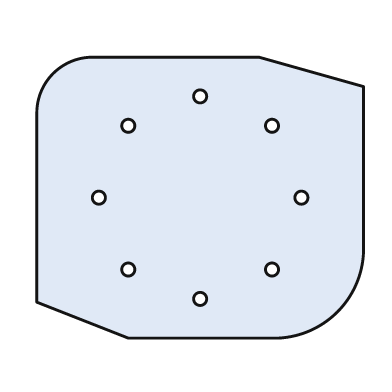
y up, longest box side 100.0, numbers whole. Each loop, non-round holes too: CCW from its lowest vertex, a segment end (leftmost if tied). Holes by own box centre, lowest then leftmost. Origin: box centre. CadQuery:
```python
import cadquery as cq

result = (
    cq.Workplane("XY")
    .moveTo(-22.0, -43.0)
    .lineTo(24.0, -43.0)
    .threePointArc((42.0, -35.0), (50.0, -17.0))
    .lineTo(50.0, 34.0)
    .lineTo(18.0, 43.0)
    .lineTo(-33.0, 43.0)
    .threePointArc((-45.0, 38.0), (-50.0, 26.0))
    .lineTo(-50.0, -32.0)
    .close()
    .moveTo(0.0, -31.0)
    .circle(2.0)
    .moveTo(-22.0, -22.0)
    .circle(2.0)
    .moveTo(22.0, -22.0)
    .circle(2.0)
    .moveTo(-31.0, 0.0)
    .circle(2.0)
    .moveTo(31.0, 0.0)
    .circle(2.0)
    .moveTo(-22.0, 22.0)
    .circle(2.0)
    .moveTo(22.0, 22.0)
    .circle(2.0)
    .moveTo(0.0, 31.0)
    .circle(2.0)
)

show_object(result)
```